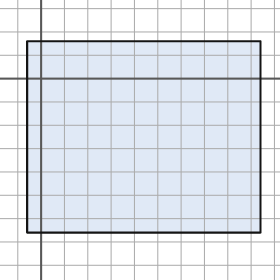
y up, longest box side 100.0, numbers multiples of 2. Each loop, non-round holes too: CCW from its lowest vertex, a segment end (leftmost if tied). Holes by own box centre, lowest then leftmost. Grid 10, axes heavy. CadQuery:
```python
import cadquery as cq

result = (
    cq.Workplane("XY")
    .moveTo(-6.0, -66.0)
    .lineTo(94.0, -66.0)
    .lineTo(94.0, 16.0)
    .lineTo(-6.0, 16.0)
    .close()
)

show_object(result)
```